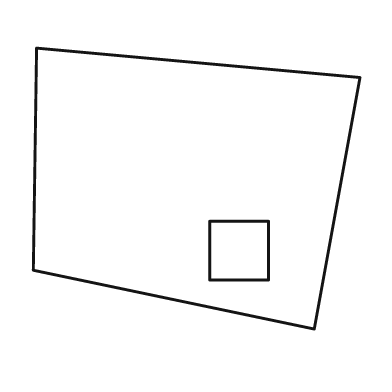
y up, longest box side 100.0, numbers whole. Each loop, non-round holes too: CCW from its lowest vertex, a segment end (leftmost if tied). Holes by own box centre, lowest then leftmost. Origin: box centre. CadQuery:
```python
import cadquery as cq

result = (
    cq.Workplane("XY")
    .moveTo(36.0, -43.0)
    .lineTo(50.0, 34.0)
    .lineTo(-49.0, 43.0)
    .lineTo(-50.0, -25.0)
    .close()
    .moveTo(4.0, -28.0)
    .lineTo(22.0, -28.0)
    .lineTo(22.0, -10.0)
    .lineTo(4.0, -10.0)
    .close()
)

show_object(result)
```